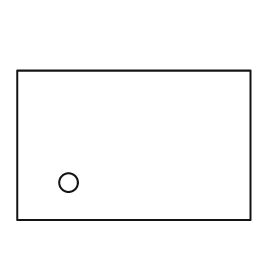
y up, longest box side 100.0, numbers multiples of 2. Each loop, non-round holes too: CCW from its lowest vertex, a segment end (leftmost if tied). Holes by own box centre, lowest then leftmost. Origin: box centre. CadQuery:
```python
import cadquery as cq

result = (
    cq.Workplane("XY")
    .moveTo(-50.0, -32.0)
    .lineTo(50.0, -32.0)
    .lineTo(50.0, 32.0)
    .lineTo(-50.0, 32.0)
    .close()
    .moveTo(-28.0, -16.0)
    .circle(4.0)
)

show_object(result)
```